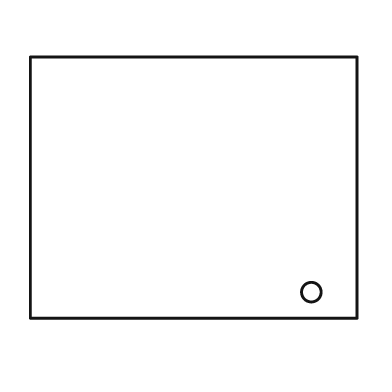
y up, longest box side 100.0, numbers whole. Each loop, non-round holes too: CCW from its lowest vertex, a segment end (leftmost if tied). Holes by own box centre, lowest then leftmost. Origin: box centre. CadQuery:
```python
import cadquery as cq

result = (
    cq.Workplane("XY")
    .moveTo(-50.0, -40.0)
    .lineTo(50.0, -40.0)
    .lineTo(50.0, 40.0)
    .lineTo(-50.0, 40.0)
    .close()
    .moveTo(36.0, -32.0)
    .circle(3.0)
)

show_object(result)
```